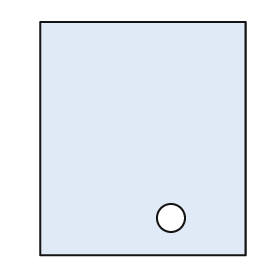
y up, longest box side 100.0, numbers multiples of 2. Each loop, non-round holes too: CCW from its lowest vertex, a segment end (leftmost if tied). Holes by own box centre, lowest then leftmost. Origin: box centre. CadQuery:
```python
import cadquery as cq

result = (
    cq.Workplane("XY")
    .moveTo(-44.0, -50.0)
    .lineTo(44.0, -50.0)
    .lineTo(44.0, 50.0)
    .lineTo(-44.0, 50.0)
    .close()
    .moveTo(12.0, -34.0)
    .circle(6.0)
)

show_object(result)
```